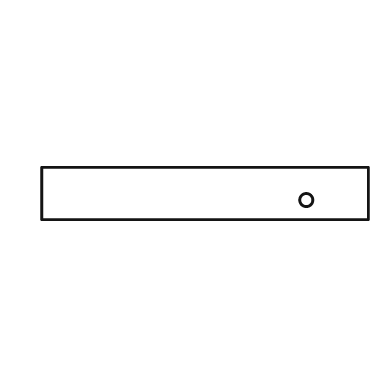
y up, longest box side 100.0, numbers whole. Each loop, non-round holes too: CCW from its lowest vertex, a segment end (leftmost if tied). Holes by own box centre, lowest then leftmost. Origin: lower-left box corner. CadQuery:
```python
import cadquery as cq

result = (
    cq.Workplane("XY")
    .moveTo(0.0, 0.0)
    .lineTo(100.0, 0.0)
    .lineTo(100.0, 16.0)
    .lineTo(0.0, 16.0)
    .close()
    .moveTo(81.0, 6.0)
    .circle(2.0)
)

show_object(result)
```